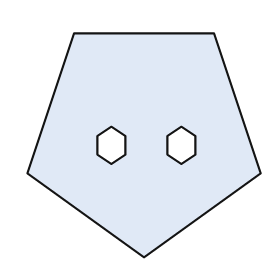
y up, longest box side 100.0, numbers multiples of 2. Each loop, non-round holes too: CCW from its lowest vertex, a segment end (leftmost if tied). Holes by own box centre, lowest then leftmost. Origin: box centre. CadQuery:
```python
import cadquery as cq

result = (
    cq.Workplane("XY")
    .moveTo(0.0, -48.0)
    .lineTo(50.0, -12.0)
    .lineTo(30.0, 48.0)
    .lineTo(-30.0, 48.0)
    .lineTo(-50.0, -12.0)
    .close()
    .moveTo(-14.0, -8.0)
    .lineTo(-8.0, -4.0)
    .lineTo(-8.0, 4.0)
    .lineTo(-14.0, 8.0)
    .lineTo(-20.0, 4.0)
    .lineTo(-20.0, -4.0)
    .close()
    .moveTo(16.0, -8.0)
    .lineTo(22.0, -4.0)
    .lineTo(22.0, 4.0)
    .lineTo(16.0, 8.0)
    .lineTo(10.0, 4.0)
    .lineTo(10.0, -4.0)
    .close()
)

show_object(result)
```